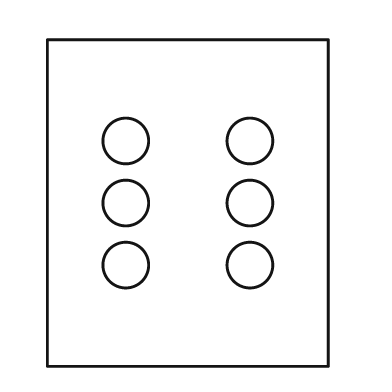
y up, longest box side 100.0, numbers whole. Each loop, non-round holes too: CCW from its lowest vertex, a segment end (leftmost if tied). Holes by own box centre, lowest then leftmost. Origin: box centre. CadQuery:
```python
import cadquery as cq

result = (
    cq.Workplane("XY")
    .moveTo(-43.0, -50.0)
    .lineTo(43.0, -50.0)
    .lineTo(43.0, 50.0)
    .lineTo(-43.0, 50.0)
    .close()
    .moveTo(-19.0, -19.0)
    .circle(7.0)
    .moveTo(19.0, -19.0)
    .circle(7.0)
    .moveTo(-19.0, 0.0)
    .circle(7.0)
    .moveTo(19.0, 0.0)
    .circle(7.0)
    .moveTo(-19.0, 19.0)
    .circle(7.0)
    .moveTo(19.0, 19.0)
    .circle(7.0)
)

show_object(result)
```